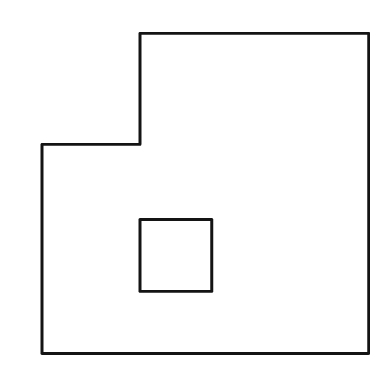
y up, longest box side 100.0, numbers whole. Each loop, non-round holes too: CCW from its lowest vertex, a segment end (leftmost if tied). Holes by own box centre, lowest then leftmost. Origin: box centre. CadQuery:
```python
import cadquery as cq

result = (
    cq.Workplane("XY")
    .moveTo(-50.0, -49.0)
    .lineTo(50.0, -49.0)
    .lineTo(50.0, 49.0)
    .lineTo(-20.0, 49.0)
    .lineTo(-20.0, 15.0)
    .lineTo(-50.0, 15.0)
    .close()
    .moveTo(-20.0, -30.0)
    .lineTo(2.0, -30.0)
    .lineTo(2.0, -8.0)
    .lineTo(-20.0, -8.0)
    .close()
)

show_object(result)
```